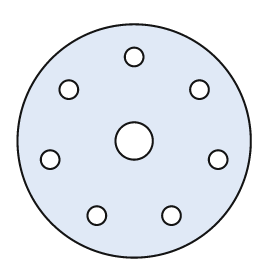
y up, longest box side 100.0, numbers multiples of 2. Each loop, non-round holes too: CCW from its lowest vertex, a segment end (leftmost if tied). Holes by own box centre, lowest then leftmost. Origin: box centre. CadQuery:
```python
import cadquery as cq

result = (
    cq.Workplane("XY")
    .moveTo(0.0, 0.0)
    .circle(50.0)
    .moveTo(-16.0, -32.0)
    .circle(4.0)
    .moveTo(16.0, -32.0)
    .circle(4.0)
    .moveTo(-36.0, -8.0)
    .circle(4.0)
    .moveTo(36.0, -8.0)
    .circle(4.0)
    .moveTo(0.0, 0.0)
    .circle(8.0)
    .moveTo(-28.0, 22.0)
    .circle(4.0)
    .moveTo(28.0, 22.0)
    .circle(4.0)
    .moveTo(0.0, 36.0)
    .circle(4.0)
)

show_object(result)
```